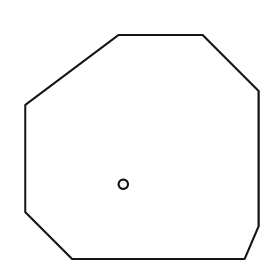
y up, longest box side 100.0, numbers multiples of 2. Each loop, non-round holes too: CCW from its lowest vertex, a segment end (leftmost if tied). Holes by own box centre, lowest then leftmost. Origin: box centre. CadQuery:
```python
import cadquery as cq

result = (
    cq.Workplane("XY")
    .moveTo(-30.0, -48.0)
    .lineTo(44.0, -48.0)
    .lineTo(50.0, -34.0)
    .lineTo(50.0, 24.0)
    .lineTo(26.0, 48.0)
    .lineTo(-10.0, 48.0)
    .lineTo(-50.0, 18.0)
    .lineTo(-50.0, -28.0)
    .close()
    .moveTo(-8.0, -16.0)
    .circle(2.0)
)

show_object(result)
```